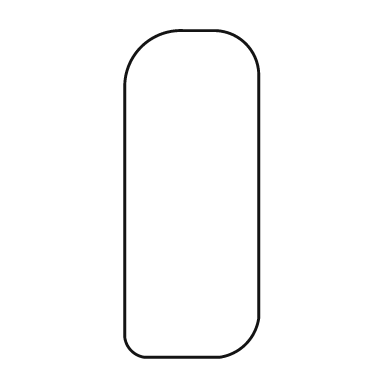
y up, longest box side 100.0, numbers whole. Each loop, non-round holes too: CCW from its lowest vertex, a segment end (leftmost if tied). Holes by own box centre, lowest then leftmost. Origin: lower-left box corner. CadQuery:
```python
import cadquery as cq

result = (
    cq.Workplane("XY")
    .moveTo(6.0, 0.0)
    .lineTo(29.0, 0.0)
    .threePointArc((37.0, 4.0), (41.0, 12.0))
    .lineTo(41.0, 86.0)
    .threePointArc((37.0, 96.0), (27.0, 100.0))
    .lineTo(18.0, 100.0)
    .threePointArc((5.0, 95.0), (0.0, 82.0))
    .lineTo(0.0, 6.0)
    .threePointArc((2.0, 2.0), (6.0, 0.0))
    .close()
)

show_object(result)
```